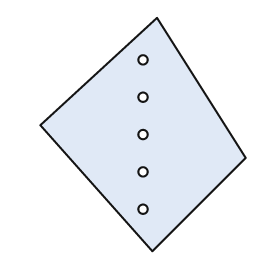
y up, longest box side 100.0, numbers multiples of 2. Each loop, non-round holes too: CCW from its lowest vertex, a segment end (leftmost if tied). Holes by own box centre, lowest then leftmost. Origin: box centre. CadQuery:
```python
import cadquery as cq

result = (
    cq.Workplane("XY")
    .moveTo(4.0, -50.0)
    .lineTo(44.0, -10.0)
    .lineTo(6.0, 50.0)
    .lineTo(-44.0, 4.0)
    .close()
    .moveTo(0.0, -32.0)
    .circle(2.0)
    .moveTo(0.0, -16.0)
    .circle(2.0)
    .moveTo(0.0, 0.0)
    .circle(2.0)
    .moveTo(0.0, 16.0)
    .circle(2.0)
    .moveTo(0.0, 32.0)
    .circle(2.0)
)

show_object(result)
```